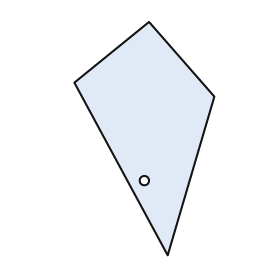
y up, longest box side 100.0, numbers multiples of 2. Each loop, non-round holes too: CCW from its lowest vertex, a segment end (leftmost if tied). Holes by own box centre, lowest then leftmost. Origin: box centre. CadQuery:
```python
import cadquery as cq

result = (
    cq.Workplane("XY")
    .moveTo(10.0, -50.0)
    .lineTo(30.0, 18.0)
    .lineTo(2.0, 50.0)
    .lineTo(-30.0, 24.0)
    .close()
    .moveTo(0.0, -18.0)
    .circle(2.0)
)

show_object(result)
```